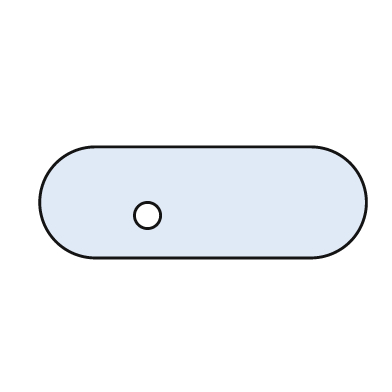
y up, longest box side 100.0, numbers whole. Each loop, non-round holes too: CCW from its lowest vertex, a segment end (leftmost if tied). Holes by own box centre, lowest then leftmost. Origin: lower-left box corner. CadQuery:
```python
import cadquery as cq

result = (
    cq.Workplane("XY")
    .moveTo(17.0, 0.0)
    .lineTo(83.0, 0.0)
    .threePointArc((100.0, 17.0), (83.0, 34.0))
    .lineTo(17.0, 34.0)
    .threePointArc((0.0, 17.0), (17.0, 0.0))
    .close()
    .moveTo(33.0, 13.0)
    .circle(4.0)
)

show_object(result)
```